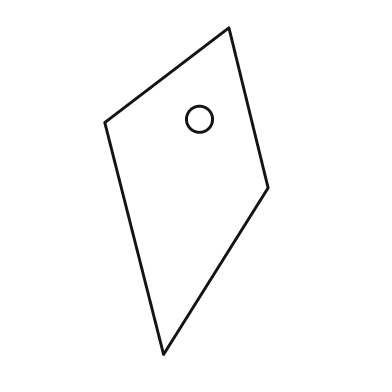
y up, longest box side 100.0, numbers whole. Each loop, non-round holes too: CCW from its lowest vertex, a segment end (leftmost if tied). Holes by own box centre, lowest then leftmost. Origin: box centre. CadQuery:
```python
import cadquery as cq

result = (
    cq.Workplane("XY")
    .moveTo(-7.0, -50.0)
    .lineTo(25.0, 1.0)
    .lineTo(13.0, 50.0)
    .lineTo(-25.0, 21.0)
    .close()
    .moveTo(4.0, 22.0)
    .circle(4.0)
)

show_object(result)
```